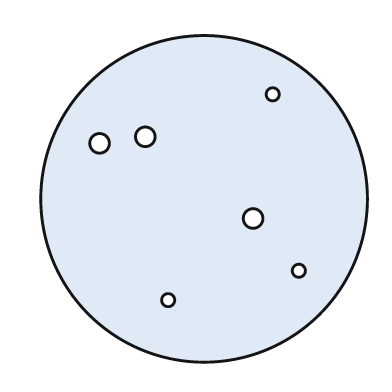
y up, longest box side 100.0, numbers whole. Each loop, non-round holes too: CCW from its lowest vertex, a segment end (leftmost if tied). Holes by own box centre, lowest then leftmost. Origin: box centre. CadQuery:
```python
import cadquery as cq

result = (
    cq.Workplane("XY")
    .moveTo(0.0, 0.0)
    .circle(50.0)
    .moveTo(-11.0, -31.0)
    .circle(2.0)
    .moveTo(29.0, -22.0)
    .circle(2.0)
    .moveTo(15.0, -6.0)
    .circle(3.0)
    .moveTo(-32.0, 17.0)
    .circle(3.0)
    .moveTo(-18.0, 19.0)
    .circle(3.0)
    .moveTo(21.0, 32.0)
    .circle(2.0)
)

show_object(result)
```